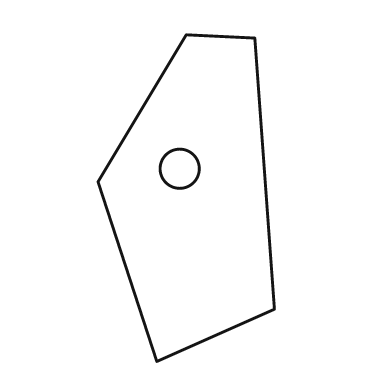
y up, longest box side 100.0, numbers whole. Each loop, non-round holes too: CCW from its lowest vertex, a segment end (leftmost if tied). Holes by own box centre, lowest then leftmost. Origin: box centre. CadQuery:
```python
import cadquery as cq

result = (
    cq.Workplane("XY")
    .moveTo(-9.0, -50.0)
    .lineTo(27.0, -34.0)
    .lineTo(21.0, 49.0)
    .lineTo(0.0, 50.0)
    .lineTo(-27.0, 5.0)
    .close()
    .moveTo(-2.0, 9.0)
    .circle(6.0)
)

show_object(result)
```